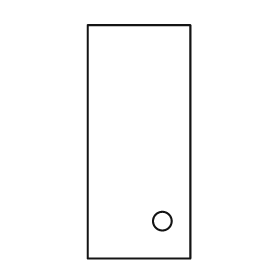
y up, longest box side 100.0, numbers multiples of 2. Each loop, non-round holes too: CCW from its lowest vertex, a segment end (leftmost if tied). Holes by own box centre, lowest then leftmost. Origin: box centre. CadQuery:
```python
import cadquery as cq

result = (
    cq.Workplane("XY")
    .moveTo(-22.0, -50.0)
    .lineTo(22.0, -50.0)
    .lineTo(22.0, 50.0)
    .lineTo(-22.0, 50.0)
    .close()
    .moveTo(10.0, -34.0)
    .circle(4.0)
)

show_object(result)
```